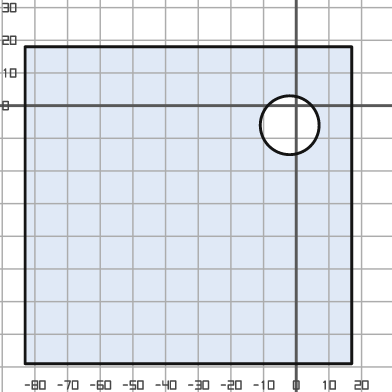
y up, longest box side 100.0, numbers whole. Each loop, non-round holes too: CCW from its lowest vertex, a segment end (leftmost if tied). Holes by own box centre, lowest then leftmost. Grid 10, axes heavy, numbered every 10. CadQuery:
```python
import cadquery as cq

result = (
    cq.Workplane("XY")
    .moveTo(-83.0, -79.0)
    .lineTo(17.0, -79.0)
    .lineTo(17.0, 18.0)
    .lineTo(-83.0, 18.0)
    .close()
    .moveTo(-2.0, -6.0)
    .circle(9.0)
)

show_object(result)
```